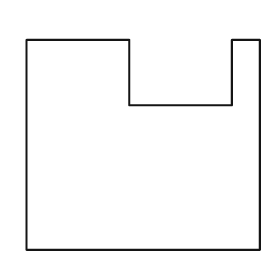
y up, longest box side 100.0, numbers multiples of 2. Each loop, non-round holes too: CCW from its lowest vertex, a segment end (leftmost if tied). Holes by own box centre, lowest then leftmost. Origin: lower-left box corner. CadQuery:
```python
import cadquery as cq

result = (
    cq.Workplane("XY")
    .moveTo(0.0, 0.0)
    .lineTo(100.0, 0.0)
    .lineTo(100.0, 90.0)
    .lineTo(88.0, 90.0)
    .lineTo(88.0, 62.0)
    .lineTo(44.0, 62.0)
    .lineTo(44.0, 90.0)
    .lineTo(0.0, 90.0)
    .close()
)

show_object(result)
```